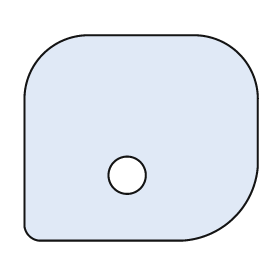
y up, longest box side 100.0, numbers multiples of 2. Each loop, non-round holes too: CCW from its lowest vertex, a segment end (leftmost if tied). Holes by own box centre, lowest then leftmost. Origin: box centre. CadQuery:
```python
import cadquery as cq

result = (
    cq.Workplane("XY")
    .moveTo(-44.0, -44.0)
    .lineTo(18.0, -44.0)
    .threePointArc((40.0, -34.0), (50.0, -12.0))
    .lineTo(50.0, 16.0)
    .threePointArc((42.0, 36.0), (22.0, 44.0))
    .lineTo(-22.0, 44.0)
    .threePointArc((-42.0, 36.0), (-50.0, 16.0))
    .lineTo(-50.0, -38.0)
    .threePointArc((-48.0, -42.0), (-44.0, -44.0))
    .close()
    .moveTo(-6.0, -16.0)
    .circle(8.0)
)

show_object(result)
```